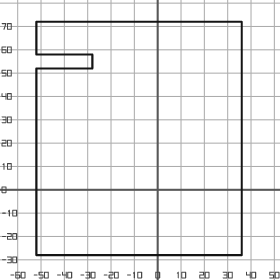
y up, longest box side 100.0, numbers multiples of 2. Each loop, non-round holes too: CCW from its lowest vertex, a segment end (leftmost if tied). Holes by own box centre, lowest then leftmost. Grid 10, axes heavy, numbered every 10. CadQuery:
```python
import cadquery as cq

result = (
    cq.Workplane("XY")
    .moveTo(-52.0, -28.0)
    .lineTo(36.0, -28.0)
    .lineTo(36.0, 72.0)
    .lineTo(-52.0, 72.0)
    .lineTo(-52.0, 58.0)
    .lineTo(-28.0, 58.0)
    .lineTo(-28.0, 52.0)
    .lineTo(-52.0, 52.0)
    .close()
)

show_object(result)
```